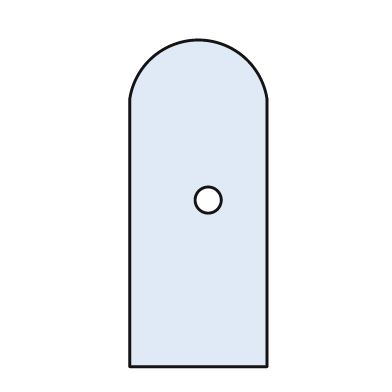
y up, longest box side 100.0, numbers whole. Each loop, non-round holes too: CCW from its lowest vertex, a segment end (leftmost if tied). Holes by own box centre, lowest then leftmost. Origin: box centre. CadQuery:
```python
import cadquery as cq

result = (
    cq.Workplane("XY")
    .moveTo(-21.0, -50.0)
    .lineTo(21.0, -50.0)
    .lineTo(21.0, 32.0)
    .threePointArc((0.0, 50.0), (-21.0, 32.0))
    .close()
    .moveTo(3.0, 1.0)
    .circle(4.0)
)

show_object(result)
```